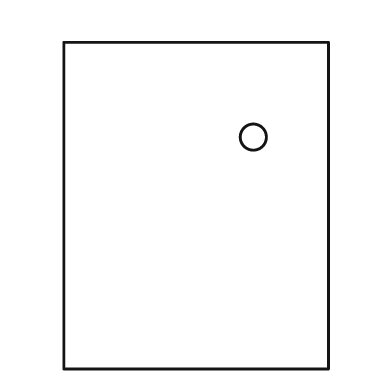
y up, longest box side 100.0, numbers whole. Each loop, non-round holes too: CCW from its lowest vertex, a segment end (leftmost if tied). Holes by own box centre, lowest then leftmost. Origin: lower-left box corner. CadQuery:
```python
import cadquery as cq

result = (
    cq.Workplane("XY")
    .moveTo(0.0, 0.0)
    .lineTo(81.0, 0.0)
    .lineTo(81.0, 100.0)
    .lineTo(0.0, 100.0)
    .close()
    .moveTo(58.0, 71.0)
    .circle(4.0)
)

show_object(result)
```